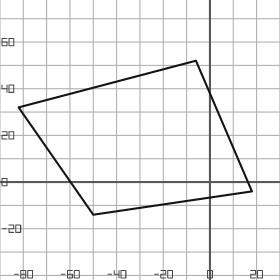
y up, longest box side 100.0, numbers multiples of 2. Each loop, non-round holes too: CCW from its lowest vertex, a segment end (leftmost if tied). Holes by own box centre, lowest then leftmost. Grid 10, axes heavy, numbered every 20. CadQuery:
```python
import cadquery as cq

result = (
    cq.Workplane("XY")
    .moveTo(-50.0, -14.0)
    .lineTo(18.0, -4.0)
    .lineTo(-6.0, 52.0)
    .lineTo(-82.0, 32.0)
    .close()
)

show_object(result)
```